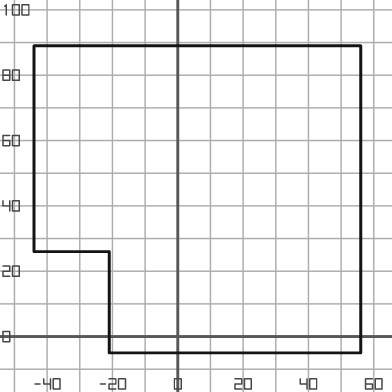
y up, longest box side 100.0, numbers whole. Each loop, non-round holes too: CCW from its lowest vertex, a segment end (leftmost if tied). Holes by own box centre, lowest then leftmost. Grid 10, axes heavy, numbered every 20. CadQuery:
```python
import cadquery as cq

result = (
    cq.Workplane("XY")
    .moveTo(-21.0, -5.0)
    .lineTo(56.0, -5.0)
    .lineTo(56.0, 89.0)
    .lineTo(-44.0, 89.0)
    .lineTo(-44.0, 26.0)
    .lineTo(-21.0, 26.0)
    .close()
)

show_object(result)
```